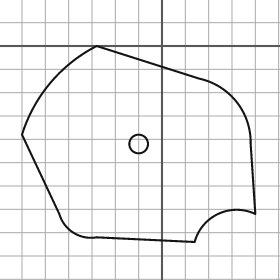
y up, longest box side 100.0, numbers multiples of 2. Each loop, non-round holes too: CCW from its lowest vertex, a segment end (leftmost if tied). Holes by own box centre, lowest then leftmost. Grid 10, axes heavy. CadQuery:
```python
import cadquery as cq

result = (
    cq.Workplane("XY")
    .moveTo(14.0, -84.0)
    .threePointArc((24.0, -72.0), (40.0, -72.0))
    .lineTo(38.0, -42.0)
    .threePointArc((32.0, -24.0), (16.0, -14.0))
    .lineTo(-28.0, 0.0)
    .threePointArc((-48.0, -16.0), (-60.0, -38.0))
    .lineTo(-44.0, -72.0)
    .threePointArc((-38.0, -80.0), (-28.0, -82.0))
    .close()
    .moveTo(-10.0, -42.0)
    .circle(4.0)
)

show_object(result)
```